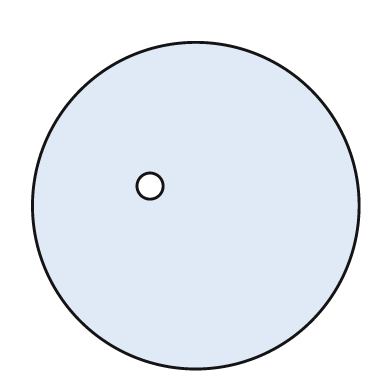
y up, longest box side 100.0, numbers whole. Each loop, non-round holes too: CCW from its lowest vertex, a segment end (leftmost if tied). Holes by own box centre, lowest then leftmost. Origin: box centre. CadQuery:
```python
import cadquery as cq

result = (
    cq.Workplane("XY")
    .moveTo(0.0, 0.0)
    .circle(50.0)
    .moveTo(-14.0, 6.0)
    .circle(4.0)
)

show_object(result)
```